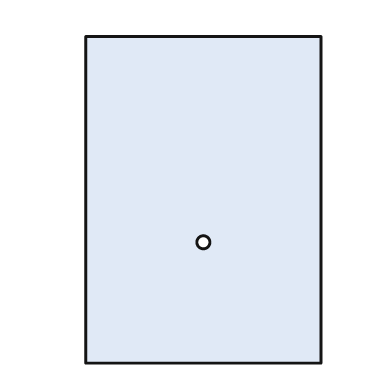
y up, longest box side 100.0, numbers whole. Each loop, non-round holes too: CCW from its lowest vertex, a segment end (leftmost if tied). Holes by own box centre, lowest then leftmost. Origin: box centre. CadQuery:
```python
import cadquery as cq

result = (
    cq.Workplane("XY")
    .moveTo(-36.0, -50.0)
    .lineTo(36.0, -50.0)
    .lineTo(36.0, 50.0)
    .lineTo(-36.0, 50.0)
    .close()
    .moveTo(0.0, -13.0)
    .circle(2.0)
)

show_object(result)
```